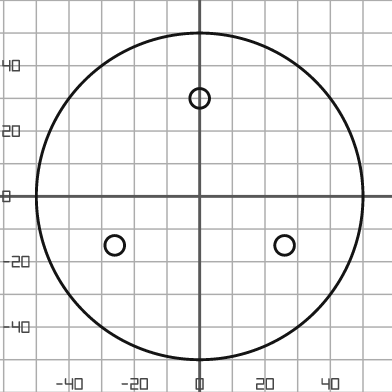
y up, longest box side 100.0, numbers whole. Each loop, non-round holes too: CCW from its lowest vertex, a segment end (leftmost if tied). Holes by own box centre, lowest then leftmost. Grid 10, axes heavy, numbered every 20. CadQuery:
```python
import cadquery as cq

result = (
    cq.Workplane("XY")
    .moveTo(0.0, 0.0)
    .circle(50.0)
    .moveTo(-26.0, -15.0)
    .circle(3.0)
    .moveTo(26.0, -15.0)
    .circle(3.0)
    .moveTo(0.0, 30.0)
    .circle(3.0)
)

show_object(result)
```